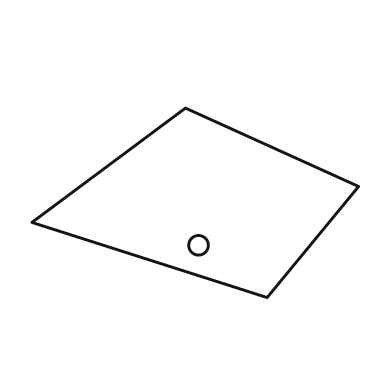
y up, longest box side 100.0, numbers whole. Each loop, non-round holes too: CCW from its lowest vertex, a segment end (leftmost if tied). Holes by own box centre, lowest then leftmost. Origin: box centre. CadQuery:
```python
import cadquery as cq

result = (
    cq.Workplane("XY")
    .moveTo(22.0, -29.0)
    .lineTo(50.0, 5.0)
    .lineTo(-3.0, 29.0)
    .lineTo(-50.0, -6.0)
    .close()
    .moveTo(1.0, -13.0)
    .circle(3.0)
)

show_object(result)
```